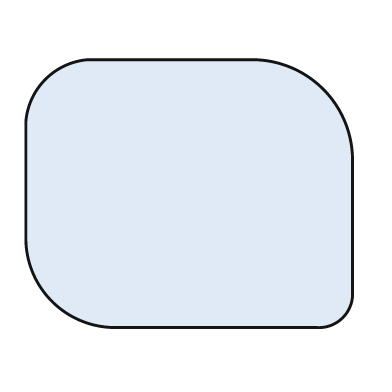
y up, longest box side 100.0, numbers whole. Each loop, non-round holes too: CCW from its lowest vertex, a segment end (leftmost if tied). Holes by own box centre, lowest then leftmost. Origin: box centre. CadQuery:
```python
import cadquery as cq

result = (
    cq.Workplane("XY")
    .moveTo(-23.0, -41.0)
    .lineTo(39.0, -41.0)
    .threePointArc((47.0, -38.0), (50.0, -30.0))
    .lineTo(50.0, 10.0)
    .threePointArc((41.0, 32.0), (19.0, 41.0))
    .lineTo(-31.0, 41.0)
    .threePointArc((-44.0, 35.0), (-50.0, 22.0))
    .lineTo(-50.0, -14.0)
    .threePointArc((-42.0, -33.0), (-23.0, -41.0))
    .close()
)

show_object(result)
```